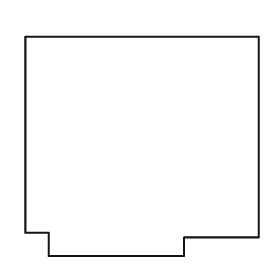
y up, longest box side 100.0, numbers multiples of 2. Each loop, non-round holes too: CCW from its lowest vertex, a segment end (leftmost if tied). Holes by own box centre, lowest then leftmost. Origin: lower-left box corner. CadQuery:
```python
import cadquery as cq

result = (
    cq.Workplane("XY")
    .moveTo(10.0, 0.0)
    .lineTo(68.0, 0.0)
    .lineTo(68.0, 8.0)
    .lineTo(100.0, 8.0)
    .lineTo(100.0, 94.0)
    .lineTo(0.0, 94.0)
    .lineTo(0.0, 10.0)
    .lineTo(10.0, 10.0)
    .close()
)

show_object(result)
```